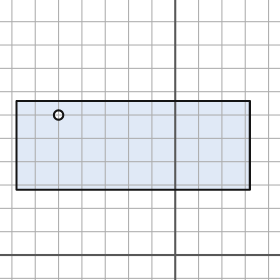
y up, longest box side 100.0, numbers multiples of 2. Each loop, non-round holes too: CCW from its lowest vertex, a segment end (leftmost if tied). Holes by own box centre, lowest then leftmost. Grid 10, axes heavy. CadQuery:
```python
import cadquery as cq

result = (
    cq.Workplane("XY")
    .moveTo(-68.0, 28.0)
    .lineTo(32.0, 28.0)
    .lineTo(32.0, 66.0)
    .lineTo(-68.0, 66.0)
    .close()
    .moveTo(-50.0, 60.0)
    .circle(2.0)
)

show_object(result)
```